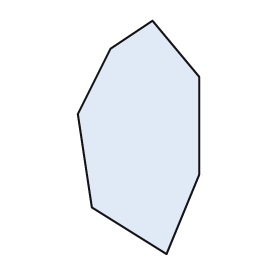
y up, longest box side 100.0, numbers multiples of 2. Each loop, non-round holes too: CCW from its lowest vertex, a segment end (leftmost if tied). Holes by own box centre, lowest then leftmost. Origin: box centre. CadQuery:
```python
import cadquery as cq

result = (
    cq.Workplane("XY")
    .moveTo(12.0, -50.0)
    .lineTo(26.0, -16.0)
    .lineTo(26.0, 26.0)
    .lineTo(6.0, 50.0)
    .lineTo(-12.0, 38.0)
    .lineTo(-26.0, 10.0)
    .lineTo(-20.0, -30.0)
    .close()
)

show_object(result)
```